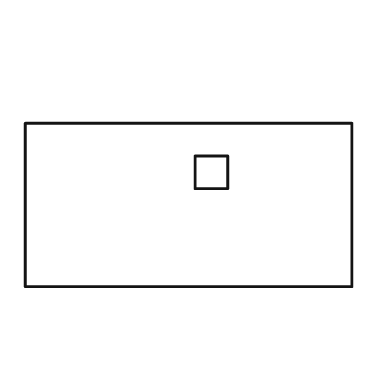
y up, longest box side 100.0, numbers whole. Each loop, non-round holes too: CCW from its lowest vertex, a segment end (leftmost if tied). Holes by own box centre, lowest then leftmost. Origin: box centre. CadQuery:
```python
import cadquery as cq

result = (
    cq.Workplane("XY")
    .moveTo(-50.0, -25.0)
    .lineTo(50.0, -25.0)
    .lineTo(50.0, 25.0)
    .lineTo(-50.0, 25.0)
    .close()
    .moveTo(2.0, 5.0)
    .lineTo(12.0, 5.0)
    .lineTo(12.0, 15.0)
    .lineTo(2.0, 15.0)
    .close()
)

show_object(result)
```